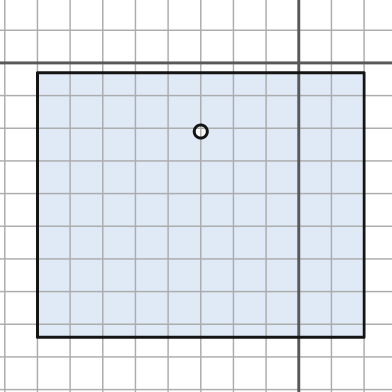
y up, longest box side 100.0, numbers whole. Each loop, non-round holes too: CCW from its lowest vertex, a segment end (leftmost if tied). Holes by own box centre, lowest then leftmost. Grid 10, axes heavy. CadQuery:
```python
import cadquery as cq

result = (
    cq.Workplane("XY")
    .moveTo(-80.0, -84.0)
    .lineTo(20.0, -84.0)
    .lineTo(20.0, -3.0)
    .lineTo(-80.0, -3.0)
    .close()
    .moveTo(-30.0, -21.0)
    .circle(2.0)
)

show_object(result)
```